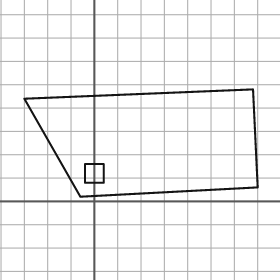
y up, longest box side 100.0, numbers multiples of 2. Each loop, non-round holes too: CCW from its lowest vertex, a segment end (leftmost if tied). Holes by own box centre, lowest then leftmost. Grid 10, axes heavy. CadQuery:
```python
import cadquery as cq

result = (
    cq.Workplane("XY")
    .moveTo(-6.0, 2.0)
    .lineTo(70.0, 6.0)
    .lineTo(68.0, 48.0)
    .lineTo(-30.0, 44.0)
    .close()
    .moveTo(-4.0, 8.0)
    .lineTo(4.0, 8.0)
    .lineTo(4.0, 16.0)
    .lineTo(-4.0, 16.0)
    .close()
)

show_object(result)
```